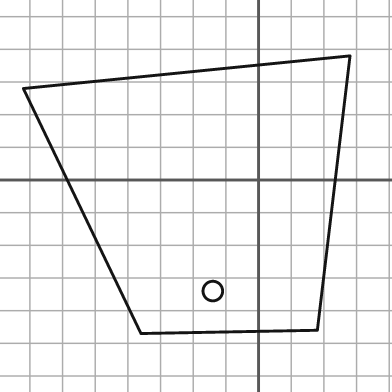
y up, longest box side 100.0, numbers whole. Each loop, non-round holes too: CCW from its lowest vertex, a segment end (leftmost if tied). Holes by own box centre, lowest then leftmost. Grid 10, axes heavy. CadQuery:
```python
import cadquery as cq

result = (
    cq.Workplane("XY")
    .moveTo(-36.0, -47.0)
    .lineTo(18.0, -46.0)
    .lineTo(28.0, 38.0)
    .lineTo(-72.0, 28.0)
    .close()
    .moveTo(-14.0, -34.0)
    .circle(3.0)
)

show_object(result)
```